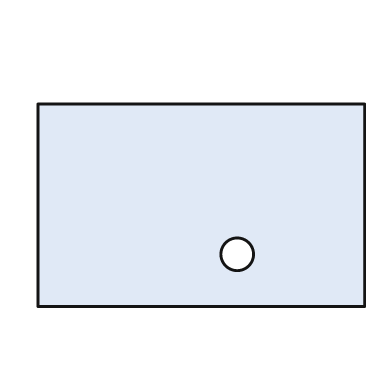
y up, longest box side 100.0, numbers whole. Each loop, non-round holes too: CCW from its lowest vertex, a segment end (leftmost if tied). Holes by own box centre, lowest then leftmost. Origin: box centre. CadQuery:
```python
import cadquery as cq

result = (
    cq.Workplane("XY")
    .moveTo(-50.0, -31.0)
    .lineTo(50.0, -31.0)
    .lineTo(50.0, 31.0)
    .lineTo(-50.0, 31.0)
    .close()
    .moveTo(11.0, -15.0)
    .circle(5.0)
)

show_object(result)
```